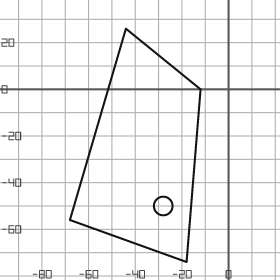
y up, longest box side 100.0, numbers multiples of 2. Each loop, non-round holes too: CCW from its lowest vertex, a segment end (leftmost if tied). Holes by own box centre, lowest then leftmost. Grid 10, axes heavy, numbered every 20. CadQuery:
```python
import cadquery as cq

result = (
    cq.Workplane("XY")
    .moveTo(-18.0, -74.0)
    .lineTo(-12.0, 0.0)
    .lineTo(-44.0, 26.0)
    .lineTo(-68.0, -56.0)
    .close()
    .moveTo(-28.0, -50.0)
    .circle(4.0)
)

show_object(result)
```